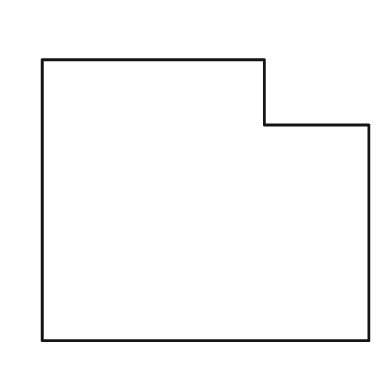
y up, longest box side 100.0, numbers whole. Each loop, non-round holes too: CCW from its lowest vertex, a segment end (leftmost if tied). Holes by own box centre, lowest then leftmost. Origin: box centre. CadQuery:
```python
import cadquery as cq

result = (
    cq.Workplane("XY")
    .moveTo(-50.0, -43.0)
    .lineTo(50.0, -43.0)
    .lineTo(50.0, 23.0)
    .lineTo(18.0, 23.0)
    .lineTo(18.0, 43.0)
    .lineTo(-50.0, 43.0)
    .close()
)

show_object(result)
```